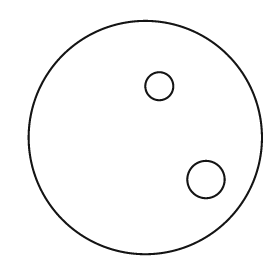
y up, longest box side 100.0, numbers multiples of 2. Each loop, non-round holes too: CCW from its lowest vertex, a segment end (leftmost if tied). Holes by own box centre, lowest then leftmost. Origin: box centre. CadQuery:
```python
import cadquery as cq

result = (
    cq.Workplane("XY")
    .moveTo(0.0, 0.0)
    .circle(50.0)
    .moveTo(26.0, -18.0)
    .circle(8.0)
    .moveTo(6.0, 22.0)
    .circle(6.0)
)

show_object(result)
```